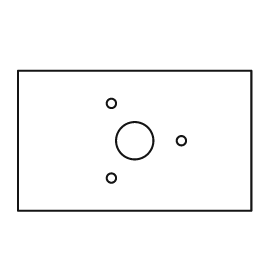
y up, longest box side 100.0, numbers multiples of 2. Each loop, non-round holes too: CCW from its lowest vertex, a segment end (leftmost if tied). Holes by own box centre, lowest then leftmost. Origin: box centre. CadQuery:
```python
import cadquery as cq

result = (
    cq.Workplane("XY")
    .moveTo(-50.0, -30.0)
    .lineTo(50.0, -30.0)
    .lineTo(50.0, 30.0)
    .lineTo(-50.0, 30.0)
    .close()
    .moveTo(-10.0, -16.0)
    .circle(2.0)
    .moveTo(0.0, 0.0)
    .circle(8.0)
    .moveTo(20.0, 0.0)
    .circle(2.0)
    .moveTo(-10.0, 16.0)
    .circle(2.0)
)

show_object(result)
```